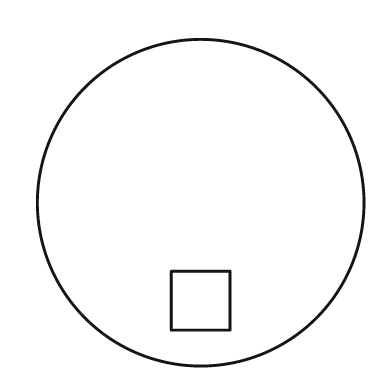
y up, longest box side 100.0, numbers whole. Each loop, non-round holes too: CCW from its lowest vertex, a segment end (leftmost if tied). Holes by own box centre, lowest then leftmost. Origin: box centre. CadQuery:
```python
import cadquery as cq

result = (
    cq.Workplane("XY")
    .moveTo(0.0, 0.0)
    .circle(50.0)
    .moveTo(-9.0, -39.0)
    .lineTo(9.0, -39.0)
    .lineTo(9.0, -21.0)
    .lineTo(-9.0, -21.0)
    .close()
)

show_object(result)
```